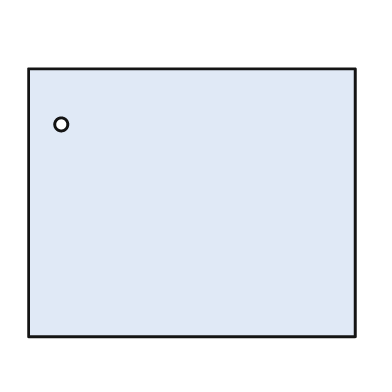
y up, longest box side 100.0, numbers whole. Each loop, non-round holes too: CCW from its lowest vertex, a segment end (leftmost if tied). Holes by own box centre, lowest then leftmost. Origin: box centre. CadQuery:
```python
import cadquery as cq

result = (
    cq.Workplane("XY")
    .moveTo(-50.0, -41.0)
    .lineTo(50.0, -41.0)
    .lineTo(50.0, 41.0)
    .lineTo(-50.0, 41.0)
    .close()
    .moveTo(-40.0, 24.0)
    .circle(2.0)
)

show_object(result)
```